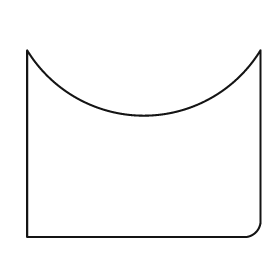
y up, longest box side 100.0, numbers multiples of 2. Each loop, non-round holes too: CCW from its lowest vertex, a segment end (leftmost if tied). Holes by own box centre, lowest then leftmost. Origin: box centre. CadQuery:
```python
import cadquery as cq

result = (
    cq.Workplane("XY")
    .moveTo(-50.0, -40.0)
    .lineTo(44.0, -40.0)
    .threePointArc((48.0, -38.0), (50.0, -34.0))
    .lineTo(50.0, 40.0)
    .threePointArc((0.0, 12.0), (-50.0, 40.0))
    .close()
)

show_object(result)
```